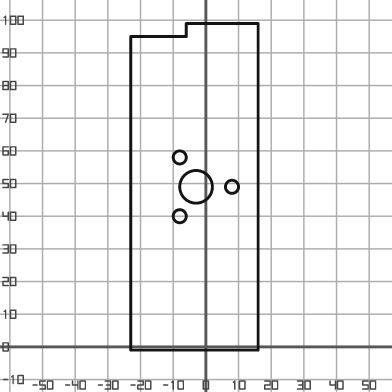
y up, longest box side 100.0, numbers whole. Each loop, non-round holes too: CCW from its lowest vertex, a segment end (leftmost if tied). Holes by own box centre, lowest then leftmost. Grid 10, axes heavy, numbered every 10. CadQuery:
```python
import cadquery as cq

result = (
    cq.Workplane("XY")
    .moveTo(-23.0, -1.0)
    .lineTo(16.0, -1.0)
    .lineTo(16.0, 99.0)
    .lineTo(-6.0, 99.0)
    .lineTo(-6.0, 95.0)
    .lineTo(-23.0, 95.0)
    .close()
    .moveTo(-8.0, 40.0)
    .circle(2.0)
    .moveTo(-3.0, 49.0)
    .circle(5.0)
    .moveTo(8.0, 49.0)
    .circle(2.0)
    .moveTo(-8.0, 58.0)
    .circle(2.0)
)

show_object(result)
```